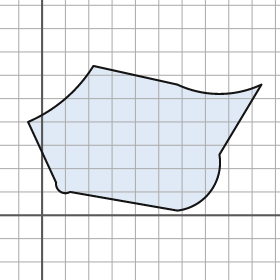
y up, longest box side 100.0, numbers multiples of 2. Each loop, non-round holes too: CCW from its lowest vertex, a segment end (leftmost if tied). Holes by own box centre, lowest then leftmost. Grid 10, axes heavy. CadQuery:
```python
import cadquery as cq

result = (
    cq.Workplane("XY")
    .moveTo(58.0, 2.0)
    .threePointArc((72.0, 10.0), (76.0, 26.0))
    .lineTo(94.0, 56.0)
    .threePointArc((76.0, 52.0), (58.0, 56.0))
    .lineTo(22.0, 64.0)
    .threePointArc((10.0, 50.0), (-6.0, 40.0))
    .lineTo(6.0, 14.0)
    .threePointArc((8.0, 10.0), (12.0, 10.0))
    .close()
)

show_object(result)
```